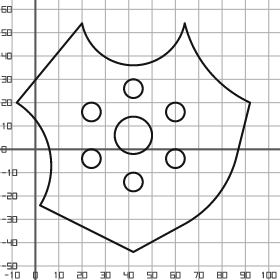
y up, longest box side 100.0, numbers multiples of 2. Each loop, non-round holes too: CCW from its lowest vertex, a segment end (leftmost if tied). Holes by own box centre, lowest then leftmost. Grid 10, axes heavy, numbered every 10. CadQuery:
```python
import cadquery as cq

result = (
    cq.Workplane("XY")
    .moveTo(42.0, -44.0)
    .lineTo(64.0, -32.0)
    .threePointArc((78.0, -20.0), (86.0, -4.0))
    .lineTo(92.0, 20.0)
    .threePointArc((74.0, 34.0), (64.0, 54.0))
    .threePointArc((42.0, 36.0), (20.0, 54.0))
    .lineTo(-8.0, 20.0)
    .threePointArc((6.0, 0.0), (2.0, -24.0))
    .close()
    .moveTo(42.0, -14.0)
    .circle(4.0)
    .moveTo(24.0, -4.0)
    .circle(4.0)
    .moveTo(60.0, -4.0)
    .circle(4.0)
    .moveTo(42.0, 6.0)
    .circle(8.0)
    .moveTo(24.0, 16.0)
    .circle(4.0)
    .moveTo(60.0, 16.0)
    .circle(4.0)
    .moveTo(42.0, 26.0)
    .circle(4.0)
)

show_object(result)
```